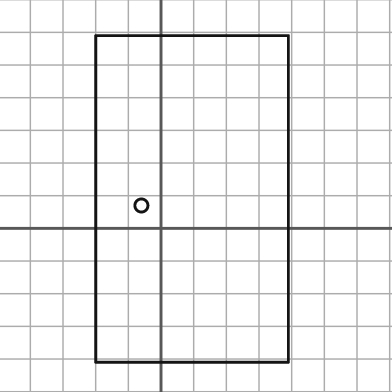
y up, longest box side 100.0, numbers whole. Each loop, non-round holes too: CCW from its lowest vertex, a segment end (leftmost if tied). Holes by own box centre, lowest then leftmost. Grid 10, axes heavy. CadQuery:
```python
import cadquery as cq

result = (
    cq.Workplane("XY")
    .moveTo(-20.0, -41.0)
    .lineTo(39.0, -41.0)
    .lineTo(39.0, 59.0)
    .lineTo(-20.0, 59.0)
    .close()
    .moveTo(-6.0, 7.0)
    .circle(2.0)
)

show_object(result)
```